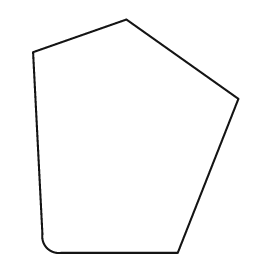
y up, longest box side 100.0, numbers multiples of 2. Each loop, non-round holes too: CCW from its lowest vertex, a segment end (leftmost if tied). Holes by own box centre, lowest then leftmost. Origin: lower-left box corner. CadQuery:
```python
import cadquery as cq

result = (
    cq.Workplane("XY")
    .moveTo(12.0, 0.0)
    .lineTo(62.0, 0.0)
    .lineTo(88.0, 66.0)
    .lineTo(40.0, 100.0)
    .lineTo(0.0, 86.0)
    .lineTo(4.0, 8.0)
    .threePointArc((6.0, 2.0), (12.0, 0.0))
    .close()
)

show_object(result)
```